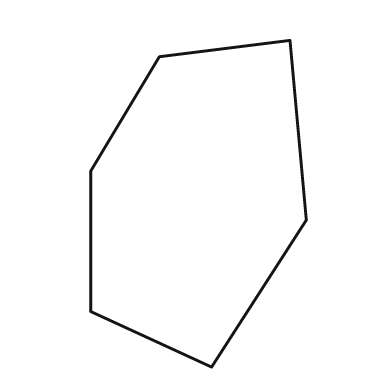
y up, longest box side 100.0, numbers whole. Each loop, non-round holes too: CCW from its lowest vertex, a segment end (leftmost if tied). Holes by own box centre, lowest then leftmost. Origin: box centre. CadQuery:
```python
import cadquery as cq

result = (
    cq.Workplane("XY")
    .moveTo(4.0, -50.0)
    .lineTo(33.0, -5.0)
    .lineTo(28.0, 50.0)
    .lineTo(-12.0, 45.0)
    .lineTo(-33.0, 10.0)
    .lineTo(-33.0, -33.0)
    .close()
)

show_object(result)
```